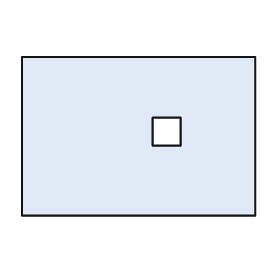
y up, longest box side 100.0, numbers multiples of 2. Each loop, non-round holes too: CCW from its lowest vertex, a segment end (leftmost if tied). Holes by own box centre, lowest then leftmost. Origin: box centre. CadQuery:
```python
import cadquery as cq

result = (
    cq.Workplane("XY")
    .moveTo(-50.0, -34.0)
    .lineTo(50.0, -34.0)
    .lineTo(50.0, 34.0)
    .lineTo(-50.0, 34.0)
    .close()
    .moveTo(6.0, -4.0)
    .lineTo(18.0, -4.0)
    .lineTo(18.0, 8.0)
    .lineTo(6.0, 8.0)
    .close()
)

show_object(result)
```